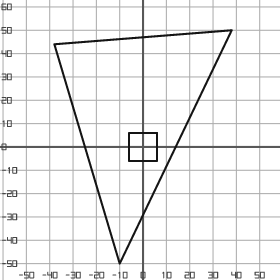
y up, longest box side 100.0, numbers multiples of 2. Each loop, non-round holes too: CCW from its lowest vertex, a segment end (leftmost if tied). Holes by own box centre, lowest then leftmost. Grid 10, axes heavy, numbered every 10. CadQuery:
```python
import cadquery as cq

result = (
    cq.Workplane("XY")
    .moveTo(-10.0, -50.0)
    .lineTo(38.0, 50.0)
    .lineTo(-38.0, 44.0)
    .close()
    .moveTo(-6.0, -6.0)
    .lineTo(6.0, -6.0)
    .lineTo(6.0, 6.0)
    .lineTo(-6.0, 6.0)
    .close()
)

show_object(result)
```